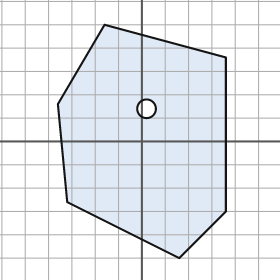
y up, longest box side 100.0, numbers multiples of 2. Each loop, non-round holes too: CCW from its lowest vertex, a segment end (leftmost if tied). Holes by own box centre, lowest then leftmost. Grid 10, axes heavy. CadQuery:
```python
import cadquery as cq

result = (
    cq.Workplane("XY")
    .moveTo(16.0, -50.0)
    .lineTo(36.0, -30.0)
    .lineTo(36.0, 36.0)
    .lineTo(-16.0, 50.0)
    .lineTo(-36.0, 16.0)
    .lineTo(-32.0, -26.0)
    .close()
    .moveTo(2.0, 14.0)
    .circle(4.0)
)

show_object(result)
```